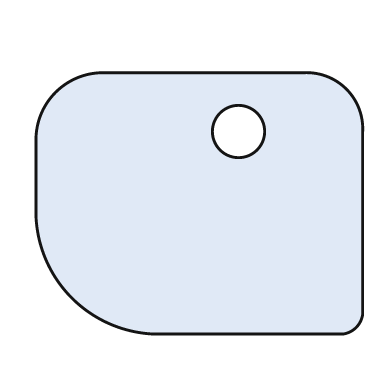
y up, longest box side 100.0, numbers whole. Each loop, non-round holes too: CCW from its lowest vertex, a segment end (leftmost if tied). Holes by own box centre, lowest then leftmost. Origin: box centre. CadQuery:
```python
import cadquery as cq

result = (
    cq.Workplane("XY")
    .moveTo(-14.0, -40.0)
    .lineTo(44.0, -40.0)
    .threePointArc((48.0, -38.0), (50.0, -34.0))
    .lineTo(50.0, 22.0)
    .threePointArc((45.0, 35.0), (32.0, 40.0))
    .lineTo(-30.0, 40.0)
    .threePointArc((-44.0, 34.0), (-50.0, 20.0))
    .lineTo(-50.0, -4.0)
    .threePointArc((-39.0, -29.0), (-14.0, -40.0))
    .close()
    .moveTo(12.0, 22.0)
    .circle(8.0)
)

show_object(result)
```